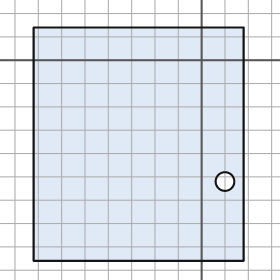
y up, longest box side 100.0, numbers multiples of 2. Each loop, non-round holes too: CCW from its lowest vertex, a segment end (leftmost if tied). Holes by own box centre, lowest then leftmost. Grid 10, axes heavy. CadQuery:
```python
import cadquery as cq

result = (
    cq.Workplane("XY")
    .moveTo(-72.0, -86.0)
    .lineTo(18.0, -86.0)
    .lineTo(18.0, 14.0)
    .lineTo(-72.0, 14.0)
    .close()
    .moveTo(10.0, -52.0)
    .circle(4.0)
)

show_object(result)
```